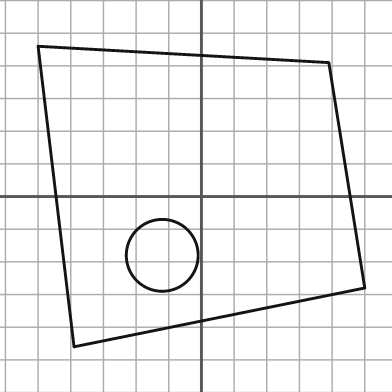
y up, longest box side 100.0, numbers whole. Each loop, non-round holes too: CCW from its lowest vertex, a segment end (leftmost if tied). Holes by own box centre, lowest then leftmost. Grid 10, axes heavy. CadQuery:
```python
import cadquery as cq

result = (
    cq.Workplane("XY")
    .moveTo(-39.0, -46.0)
    .lineTo(50.0, -28.0)
    .lineTo(39.0, 41.0)
    .lineTo(-50.0, 46.0)
    .close()
    .moveTo(-12.0, -18.0)
    .circle(11.0)
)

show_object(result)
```